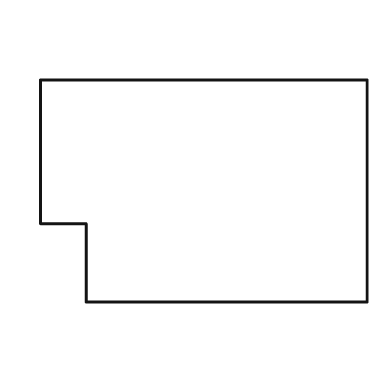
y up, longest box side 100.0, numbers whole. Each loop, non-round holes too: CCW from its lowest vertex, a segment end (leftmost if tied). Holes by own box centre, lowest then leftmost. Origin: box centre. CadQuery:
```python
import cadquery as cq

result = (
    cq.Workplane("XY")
    .moveTo(-36.0, -34.0)
    .lineTo(50.0, -34.0)
    .lineTo(50.0, 34.0)
    .lineTo(-50.0, 34.0)
    .lineTo(-50.0, -10.0)
    .lineTo(-36.0, -10.0)
    .close()
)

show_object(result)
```